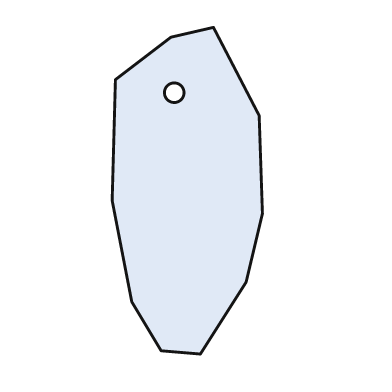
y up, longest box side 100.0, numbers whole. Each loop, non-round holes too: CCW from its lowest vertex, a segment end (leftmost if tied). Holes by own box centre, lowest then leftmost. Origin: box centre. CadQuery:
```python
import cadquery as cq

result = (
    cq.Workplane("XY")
    .moveTo(4.0, -50.0)
    .lineTo(18.0, -28.0)
    .lineTo(23.0, -7.0)
    .lineTo(22.0, 23.0)
    .lineTo(8.0, 50.0)
    .lineTo(-5.0, 47.0)
    .lineTo(-22.0, 34.0)
    .lineTo(-23.0, -3.0)
    .lineTo(-17.0, -34.0)
    .lineTo(-8.0, -49.0)
    .close()
    .moveTo(-4.0, 30.0)
    .circle(3.0)
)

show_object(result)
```